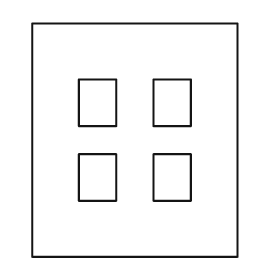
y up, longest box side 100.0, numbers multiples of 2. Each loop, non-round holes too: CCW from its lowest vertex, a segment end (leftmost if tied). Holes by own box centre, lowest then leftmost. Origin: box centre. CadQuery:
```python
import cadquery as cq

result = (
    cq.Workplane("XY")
    .moveTo(-44.0, -50.0)
    .lineTo(44.0, -50.0)
    .lineTo(44.0, 50.0)
    .lineTo(-44.0, 50.0)
    .close()
    .moveTo(-24.0, -26.0)
    .lineTo(-8.0, -26.0)
    .lineTo(-8.0, -6.0)
    .lineTo(-24.0, -6.0)
    .close()
    .moveTo(8.0, -26.0)
    .lineTo(24.0, -26.0)
    .lineTo(24.0, -6.0)
    .lineTo(8.0, -6.0)
    .close()
    .moveTo(-24.0, 6.0)
    .lineTo(-8.0, 6.0)
    .lineTo(-8.0, 26.0)
    .lineTo(-24.0, 26.0)
    .close()
    .moveTo(8.0, 6.0)
    .lineTo(24.0, 6.0)
    .lineTo(24.0, 26.0)
    .lineTo(8.0, 26.0)
    .close()
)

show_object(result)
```